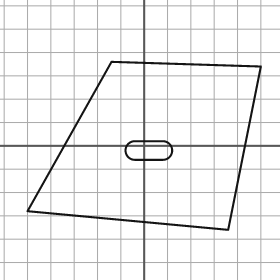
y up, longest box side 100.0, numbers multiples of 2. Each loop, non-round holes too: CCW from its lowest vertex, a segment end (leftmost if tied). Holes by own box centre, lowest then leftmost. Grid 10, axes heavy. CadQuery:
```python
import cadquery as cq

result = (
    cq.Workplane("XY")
    .moveTo(36.0, -36.0)
    .lineTo(50.0, 34.0)
    .lineTo(-14.0, 36.0)
    .lineTo(-50.0, -28.0)
    .close()
    .moveTo(-4.0, -6.0)
    .lineTo(8.0, -6.0)
    .threePointArc((12.0, -2.0), (8.0, 2.0))
    .lineTo(-4.0, 2.0)
    .threePointArc((-8.0, -2.0), (-4.0, -6.0))
    .close()
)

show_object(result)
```